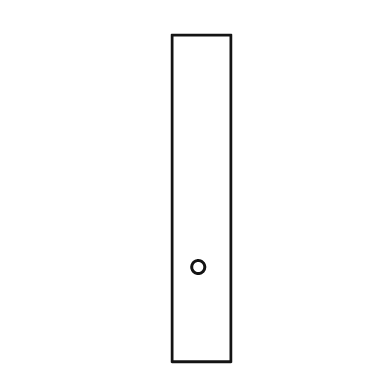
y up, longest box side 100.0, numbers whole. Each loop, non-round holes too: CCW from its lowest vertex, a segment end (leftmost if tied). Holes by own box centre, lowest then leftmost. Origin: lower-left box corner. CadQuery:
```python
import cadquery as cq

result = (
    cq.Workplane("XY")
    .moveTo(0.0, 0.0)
    .lineTo(18.0, 0.0)
    .lineTo(18.0, 100.0)
    .lineTo(0.0, 100.0)
    .close()
    .moveTo(8.0, 29.0)
    .circle(2.0)
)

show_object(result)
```